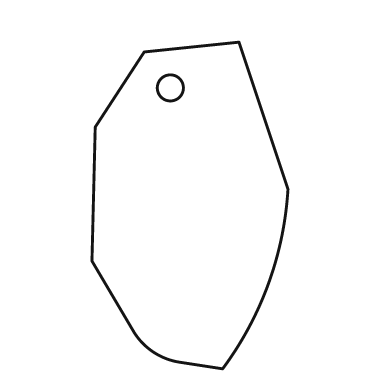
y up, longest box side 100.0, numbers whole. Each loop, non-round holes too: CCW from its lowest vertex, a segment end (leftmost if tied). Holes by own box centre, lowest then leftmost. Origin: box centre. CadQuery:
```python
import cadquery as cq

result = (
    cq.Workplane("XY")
    .moveTo(10.0, -50.0)
    .threePointArc((24.0, -24.0), (30.0, 5.0))
    .lineTo(15.0, 50.0)
    .lineTo(-14.0, 47.0)
    .lineTo(-29.0, 24.0)
    .lineTo(-30.0, -17.0)
    .lineTo(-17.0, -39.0)
    .threePointArc((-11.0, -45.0), (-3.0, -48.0))
    .close()
    .moveTo(-6.0, 36.0)
    .circle(4.0)
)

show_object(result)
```